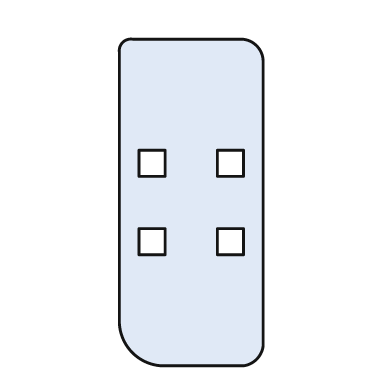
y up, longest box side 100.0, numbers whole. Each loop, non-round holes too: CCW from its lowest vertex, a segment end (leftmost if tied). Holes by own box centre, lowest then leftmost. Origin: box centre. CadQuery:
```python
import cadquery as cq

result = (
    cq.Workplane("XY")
    .moveTo(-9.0, -50.0)
    .lineTo(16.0, -50.0)
    .threePointArc((20.0, -48.0), (22.0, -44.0))
    .lineTo(22.0, 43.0)
    .threePointArc((20.0, 48.0), (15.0, 50.0))
    .lineTo(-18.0, 50.0)
    .threePointArc((-21.0, 49.0), (-22.0, 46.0))
    .lineTo(-22.0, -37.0)
    .threePointArc((-18.0, -46.0), (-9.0, -50.0))
    .close()
    .moveTo(-16.0, -16.0)
    .lineTo(-8.0, -16.0)
    .lineTo(-8.0, -8.0)
    .lineTo(-16.0, -8.0)
    .close()
    .moveTo(8.0, -16.0)
    .lineTo(16.0, -16.0)
    .lineTo(16.0, -8.0)
    .lineTo(8.0, -8.0)
    .close()
    .moveTo(-16.0, 8.0)
    .lineTo(-8.0, 8.0)
    .lineTo(-8.0, 16.0)
    .lineTo(-16.0, 16.0)
    .close()
    .moveTo(8.0, 8.0)
    .lineTo(16.0, 8.0)
    .lineTo(16.0, 16.0)
    .lineTo(8.0, 16.0)
    .close()
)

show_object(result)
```